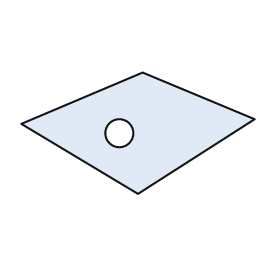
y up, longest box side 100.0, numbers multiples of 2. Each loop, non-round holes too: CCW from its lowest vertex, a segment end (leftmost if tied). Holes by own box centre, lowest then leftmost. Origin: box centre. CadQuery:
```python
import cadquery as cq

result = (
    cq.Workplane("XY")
    .moveTo(0.0, -26.0)
    .lineTo(50.0, 6.0)
    .lineTo(2.0, 26.0)
    .lineTo(-50.0, 4.0)
    .close()
    .moveTo(-8.0, 0.0)
    .circle(6.0)
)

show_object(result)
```